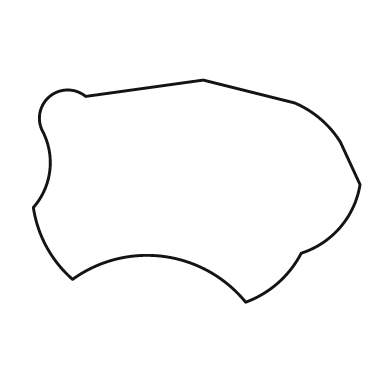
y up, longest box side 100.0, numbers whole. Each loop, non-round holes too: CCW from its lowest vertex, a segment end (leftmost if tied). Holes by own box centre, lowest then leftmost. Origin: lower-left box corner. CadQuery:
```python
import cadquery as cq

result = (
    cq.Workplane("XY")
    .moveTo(65.0, 0.0)
    .threePointArc((75.0, 6.0), (82.0, 15.0))
    .threePointArc((94.0, 23.0), (100.0, 36.0))
    .lineTo(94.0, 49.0)
    .threePointArc((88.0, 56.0), (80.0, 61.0))
    .lineTo(52.0, 68.0)
    .lineTo(16.0, 63.0)
    .threePointArc((5.0, 63.0), (3.0, 52.0))
    .threePointArc((5.0, 40.0), (0.0, 29.0))
    .threePointArc((4.0, 17.0), (12.0, 7.0))
    .threePointArc((40.0, 14.0), (65.0, 0.0))
    .close()
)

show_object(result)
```